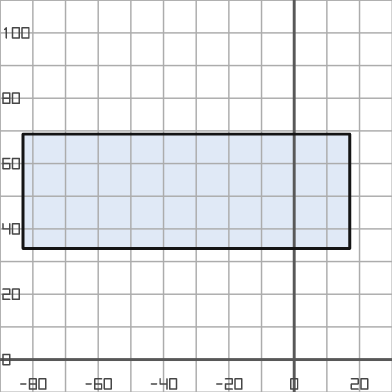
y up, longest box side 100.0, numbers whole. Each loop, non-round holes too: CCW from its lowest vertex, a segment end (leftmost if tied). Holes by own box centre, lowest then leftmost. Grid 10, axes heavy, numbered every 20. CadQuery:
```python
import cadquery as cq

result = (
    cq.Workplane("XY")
    .moveTo(-83.0, 34.0)
    .lineTo(17.0, 34.0)
    .lineTo(17.0, 69.0)
    .lineTo(-83.0, 69.0)
    .close()
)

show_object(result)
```